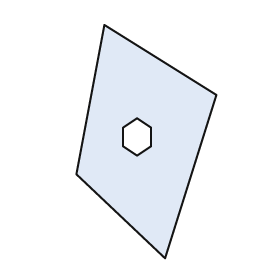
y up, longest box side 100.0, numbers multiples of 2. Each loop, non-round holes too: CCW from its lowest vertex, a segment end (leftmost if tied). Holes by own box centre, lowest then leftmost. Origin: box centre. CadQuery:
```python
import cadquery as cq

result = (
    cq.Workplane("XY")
    .moveTo(8.0, -50.0)
    .lineTo(30.0, 20.0)
    .lineTo(-18.0, 50.0)
    .lineTo(-30.0, -14.0)
    .close()
    .moveTo(-4.0, -6.0)
    .lineTo(2.0, -2.0)
    .lineTo(2.0, 6.0)
    .lineTo(-4.0, 10.0)
    .lineTo(-10.0, 6.0)
    .lineTo(-10.0, -2.0)
    .close()
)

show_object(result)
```